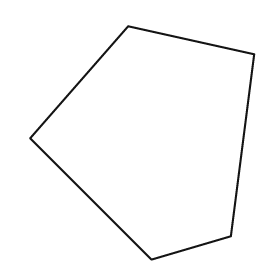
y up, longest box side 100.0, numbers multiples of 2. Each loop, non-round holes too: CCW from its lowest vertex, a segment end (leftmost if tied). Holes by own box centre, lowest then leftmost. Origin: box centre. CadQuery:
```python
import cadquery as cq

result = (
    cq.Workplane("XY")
    .moveTo(4.0, -50.0)
    .lineTo(38.0, -40.0)
    .lineTo(48.0, 38.0)
    .lineTo(-6.0, 50.0)
    .lineTo(-48.0, 2.0)
    .close()
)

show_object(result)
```